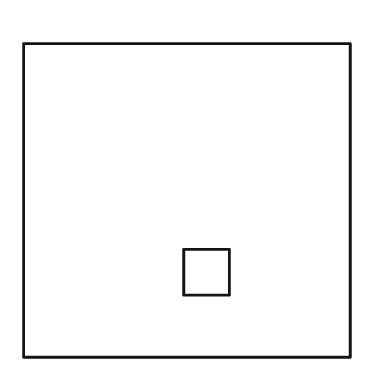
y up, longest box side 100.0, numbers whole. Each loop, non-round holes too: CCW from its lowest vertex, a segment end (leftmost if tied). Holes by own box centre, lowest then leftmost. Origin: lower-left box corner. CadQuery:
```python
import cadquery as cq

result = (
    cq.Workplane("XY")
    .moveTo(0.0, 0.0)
    .lineTo(100.0, 0.0)
    .lineTo(100.0, 96.0)
    .lineTo(0.0, 96.0)
    .close()
    .moveTo(49.0, 19.0)
    .lineTo(63.0, 19.0)
    .lineTo(63.0, 33.0)
    .lineTo(49.0, 33.0)
    .close()
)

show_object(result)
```